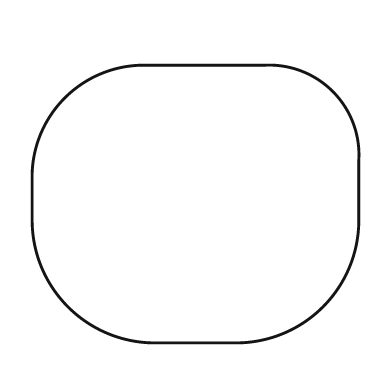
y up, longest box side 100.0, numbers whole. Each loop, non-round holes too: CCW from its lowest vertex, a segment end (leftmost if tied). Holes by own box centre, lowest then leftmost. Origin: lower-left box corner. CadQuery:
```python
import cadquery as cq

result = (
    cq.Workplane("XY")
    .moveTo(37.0, 0.0)
    .lineTo(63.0, 0.0)
    .threePointArc((89.0, 11.0), (100.0, 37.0))
    .lineTo(100.0, 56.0)
    .threePointArc((92.0, 77.0), (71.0, 85.0))
    .lineTo(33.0, 85.0)
    .threePointArc((10.0, 75.0), (0.0, 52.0))
    .lineTo(0.0, 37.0)
    .threePointArc((11.0, 11.0), (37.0, 0.0))
    .close()
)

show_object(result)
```